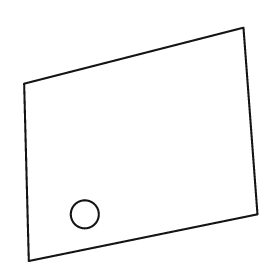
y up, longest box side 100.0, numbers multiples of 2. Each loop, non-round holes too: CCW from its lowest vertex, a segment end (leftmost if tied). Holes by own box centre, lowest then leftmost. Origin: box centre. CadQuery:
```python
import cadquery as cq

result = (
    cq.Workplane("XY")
    .moveTo(-48.0, -50.0)
    .lineTo(50.0, -30.0)
    .lineTo(44.0, 50.0)
    .lineTo(-50.0, 26.0)
    .close()
    .moveTo(-24.0, -30.0)
    .circle(6.0)
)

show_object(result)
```